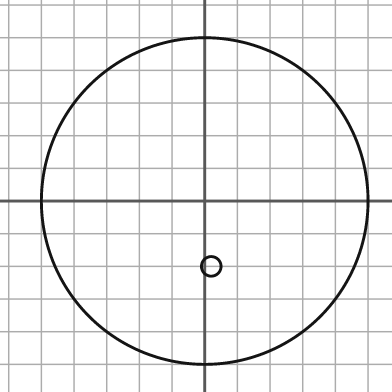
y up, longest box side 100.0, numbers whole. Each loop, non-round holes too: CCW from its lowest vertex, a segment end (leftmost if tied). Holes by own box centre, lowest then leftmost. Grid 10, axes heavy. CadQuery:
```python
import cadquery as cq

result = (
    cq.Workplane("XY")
    .moveTo(0.0, 0.0)
    .circle(50.0)
    .moveTo(2.0, -20.0)
    .circle(3.0)
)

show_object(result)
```